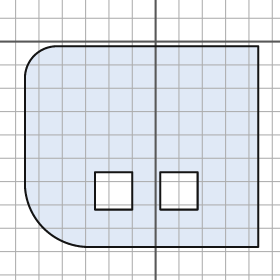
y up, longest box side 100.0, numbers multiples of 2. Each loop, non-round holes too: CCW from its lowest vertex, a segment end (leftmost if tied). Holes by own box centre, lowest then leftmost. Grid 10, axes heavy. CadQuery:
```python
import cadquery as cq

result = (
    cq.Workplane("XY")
    .moveTo(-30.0, -88.0)
    .lineTo(44.0, -88.0)
    .lineTo(44.0, -2.0)
    .lineTo(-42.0, -2.0)
    .threePointArc((-52.0, -6.0), (-56.0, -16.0))
    .lineTo(-56.0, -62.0)
    .threePointArc((-48.0, -80.0), (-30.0, -88.0))
    .close()
    .moveTo(-26.0, -72.0)
    .lineTo(-10.0, -72.0)
    .lineTo(-10.0, -56.0)
    .lineTo(-26.0, -56.0)
    .close()
    .moveTo(2.0, -72.0)
    .lineTo(18.0, -72.0)
    .lineTo(18.0, -56.0)
    .lineTo(2.0, -56.0)
    .close()
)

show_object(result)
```